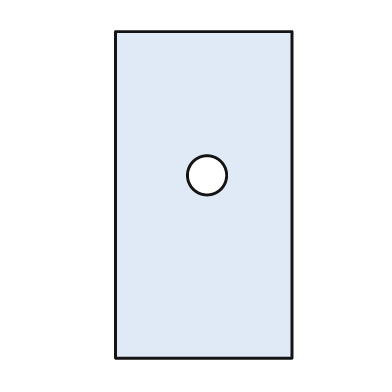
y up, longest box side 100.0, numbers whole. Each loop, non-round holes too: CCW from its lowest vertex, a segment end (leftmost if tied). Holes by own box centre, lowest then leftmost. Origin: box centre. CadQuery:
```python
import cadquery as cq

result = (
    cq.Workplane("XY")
    .moveTo(-27.0, -50.0)
    .lineTo(27.0, -50.0)
    .lineTo(27.0, 50.0)
    .lineTo(-27.0, 50.0)
    .close()
    .moveTo(1.0, 6.0)
    .circle(6.0)
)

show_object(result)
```